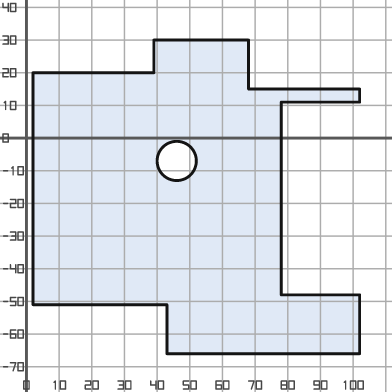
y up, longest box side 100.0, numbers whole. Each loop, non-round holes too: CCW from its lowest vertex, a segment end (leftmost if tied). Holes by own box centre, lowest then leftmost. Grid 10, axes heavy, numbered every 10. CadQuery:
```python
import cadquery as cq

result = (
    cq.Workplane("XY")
    .moveTo(43.0, -66.0)
    .lineTo(102.0, -66.0)
    .lineTo(102.0, -48.0)
    .lineTo(78.0, -48.0)
    .lineTo(78.0, 11.0)
    .lineTo(102.0, 11.0)
    .lineTo(102.0, 15.0)
    .lineTo(68.0, 15.0)
    .lineTo(68.0, 30.0)
    .lineTo(39.0, 30.0)
    .lineTo(39.0, 20.0)
    .lineTo(2.0, 20.0)
    .lineTo(2.0, -51.0)
    .lineTo(43.0, -51.0)
    .close()
    .moveTo(46.0, -7.0)
    .circle(6.0)
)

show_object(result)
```